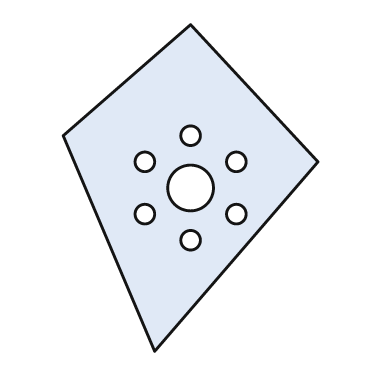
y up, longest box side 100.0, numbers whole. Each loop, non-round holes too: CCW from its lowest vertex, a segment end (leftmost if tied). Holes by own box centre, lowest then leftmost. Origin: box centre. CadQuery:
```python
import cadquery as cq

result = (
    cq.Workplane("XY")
    .moveTo(-11.0, -50.0)
    .lineTo(39.0, 8.0)
    .lineTo(0.0, 50.0)
    .lineTo(-39.0, 16.0)
    .close()
    .moveTo(0.0, -16.0)
    .circle(3.0)
    .moveTo(-14.0, -8.0)
    .circle(3.0)
    .moveTo(14.0, -8.0)
    .circle(3.0)
    .moveTo(0.0, 0.0)
    .circle(7.0)
    .moveTo(-14.0, 8.0)
    .circle(3.0)
    .moveTo(14.0, 8.0)
    .circle(3.0)
    .moveTo(0.0, 16.0)
    .circle(3.0)
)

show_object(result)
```